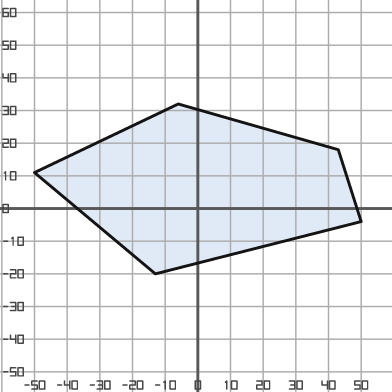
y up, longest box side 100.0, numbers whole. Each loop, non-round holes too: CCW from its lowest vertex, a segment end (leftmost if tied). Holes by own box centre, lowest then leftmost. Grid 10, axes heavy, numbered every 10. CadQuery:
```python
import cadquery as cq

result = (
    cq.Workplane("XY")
    .moveTo(-13.0, -20.0)
    .lineTo(50.0, -4.0)
    .lineTo(43.0, 18.0)
    .lineTo(-6.0, 32.0)
    .lineTo(-50.0, 11.0)
    .close()
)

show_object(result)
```